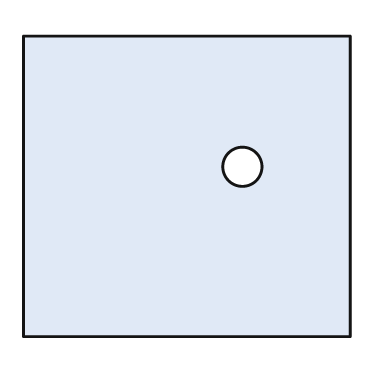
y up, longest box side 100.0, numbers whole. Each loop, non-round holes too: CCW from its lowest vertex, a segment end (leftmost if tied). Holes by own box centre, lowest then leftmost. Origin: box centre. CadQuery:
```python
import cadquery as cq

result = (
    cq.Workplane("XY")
    .moveTo(-50.0, -46.0)
    .lineTo(50.0, -46.0)
    .lineTo(50.0, 46.0)
    .lineTo(-50.0, 46.0)
    .close()
    .moveTo(17.0, 6.0)
    .circle(6.0)
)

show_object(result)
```